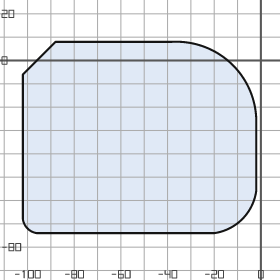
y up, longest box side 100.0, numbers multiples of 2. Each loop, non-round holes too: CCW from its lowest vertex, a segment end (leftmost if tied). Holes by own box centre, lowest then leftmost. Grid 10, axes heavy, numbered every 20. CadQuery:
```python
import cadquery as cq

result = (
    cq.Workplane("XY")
    .moveTo(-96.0, -74.0)
    .lineTo(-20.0, -74.0)
    .threePointArc((-8.0, -68.0), (-2.0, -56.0))
    .lineTo(-2.0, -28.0)
    .threePointArc((-12.0, -2.0), (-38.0, 8.0))
    .lineTo(-88.0, 8.0)
    .lineTo(-102.0, -6.0)
    .lineTo(-102.0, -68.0)
    .threePointArc((-100.0, -72.0), (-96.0, -74.0))
    .close()
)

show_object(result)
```